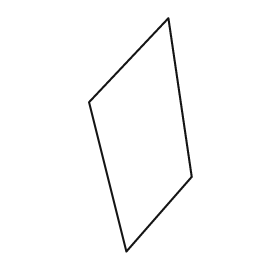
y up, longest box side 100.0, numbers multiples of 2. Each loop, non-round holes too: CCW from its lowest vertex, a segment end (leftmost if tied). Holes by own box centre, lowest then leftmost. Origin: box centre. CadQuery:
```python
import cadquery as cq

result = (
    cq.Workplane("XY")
    .moveTo(-6.0, -50.0)
    .lineTo(22.0, -18.0)
    .lineTo(12.0, 50.0)
    .lineTo(-22.0, 14.0)
    .close()
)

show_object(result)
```